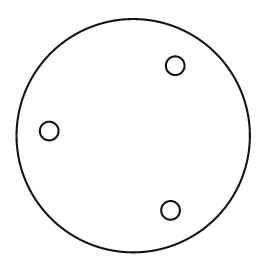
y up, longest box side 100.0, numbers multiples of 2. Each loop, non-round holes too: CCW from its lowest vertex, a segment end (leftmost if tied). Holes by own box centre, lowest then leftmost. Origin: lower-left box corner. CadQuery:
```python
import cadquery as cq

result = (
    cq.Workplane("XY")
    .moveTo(50.0, 50.0)
    .circle(50.0)
    .moveTo(66.0, 18.0)
    .circle(4.0)
    .moveTo(14.0, 52.0)
    .circle(4.0)
    .moveTo(68.0, 80.0)
    .circle(4.0)
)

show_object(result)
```